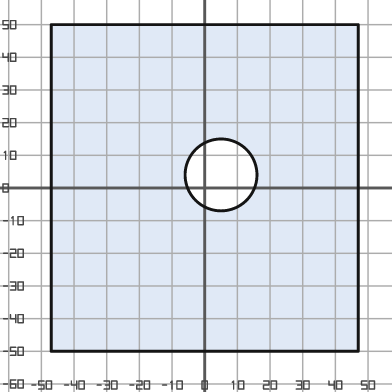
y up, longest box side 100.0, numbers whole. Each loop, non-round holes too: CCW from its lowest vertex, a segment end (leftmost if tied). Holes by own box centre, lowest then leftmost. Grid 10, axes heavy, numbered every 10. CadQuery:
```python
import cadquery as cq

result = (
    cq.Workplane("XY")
    .moveTo(-47.0, -50.0)
    .lineTo(47.0, -50.0)
    .lineTo(47.0, 50.0)
    .lineTo(-47.0, 50.0)
    .close()
    .moveTo(5.0, 4.0)
    .circle(11.0)
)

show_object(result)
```